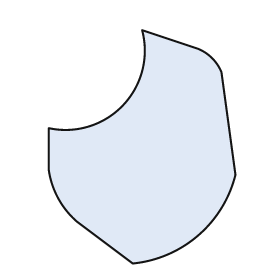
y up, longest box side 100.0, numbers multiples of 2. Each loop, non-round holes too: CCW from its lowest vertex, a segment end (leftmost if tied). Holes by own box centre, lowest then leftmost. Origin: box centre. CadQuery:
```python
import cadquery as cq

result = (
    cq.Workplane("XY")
    .moveTo(-4.0, -50.0)
    .threePointArc((24.0, -38.0), (40.0, -12.0))
    .lineTo(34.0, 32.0)
    .threePointArc((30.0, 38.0), (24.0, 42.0))
    .lineTo(0.0, 50.0)
    .threePointArc((-8.0, 18.0), (-40.0, 8.0))
    .lineTo(-40.0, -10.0)
    .threePointArc((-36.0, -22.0), (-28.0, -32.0))
    .close()
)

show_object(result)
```